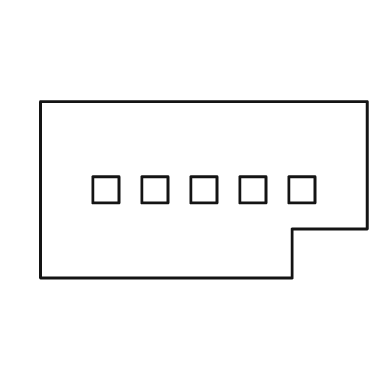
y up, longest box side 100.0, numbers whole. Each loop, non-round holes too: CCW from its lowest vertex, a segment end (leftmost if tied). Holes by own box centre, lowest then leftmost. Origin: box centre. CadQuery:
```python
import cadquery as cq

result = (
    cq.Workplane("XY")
    .moveTo(-50.0, -27.0)
    .lineTo(27.0, -27.0)
    .lineTo(27.0, -12.0)
    .lineTo(50.0, -12.0)
    .lineTo(50.0, 27.0)
    .lineTo(-50.0, 27.0)
    .close()
    .moveTo(-34.0, -4.0)
    .lineTo(-26.0, -4.0)
    .lineTo(-26.0, 4.0)
    .lineTo(-34.0, 4.0)
    .close()
    .moveTo(-19.0, -4.0)
    .lineTo(-11.0, -4.0)
    .lineTo(-11.0, 4.0)
    .lineTo(-19.0, 4.0)
    .close()
    .moveTo(-4.0, -4.0)
    .lineTo(4.0, -4.0)
    .lineTo(4.0, 4.0)
    .lineTo(-4.0, 4.0)
    .close()
    .moveTo(11.0, -4.0)
    .lineTo(19.0, -4.0)
    .lineTo(19.0, 4.0)
    .lineTo(11.0, 4.0)
    .close()
    .moveTo(26.0, -4.0)
    .lineTo(34.0, -4.0)
    .lineTo(34.0, 4.0)
    .lineTo(26.0, 4.0)
    .close()
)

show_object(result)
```